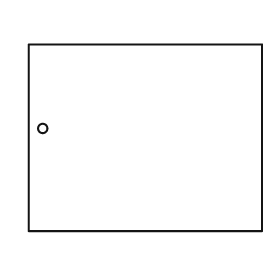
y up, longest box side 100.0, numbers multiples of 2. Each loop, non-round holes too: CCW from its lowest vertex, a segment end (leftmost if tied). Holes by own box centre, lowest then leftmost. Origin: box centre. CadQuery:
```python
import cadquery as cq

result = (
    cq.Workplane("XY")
    .moveTo(-50.0, -40.0)
    .lineTo(50.0, -40.0)
    .lineTo(50.0, 40.0)
    .lineTo(-50.0, 40.0)
    .close()
    .moveTo(-44.0, 4.0)
    .circle(2.0)
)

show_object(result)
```